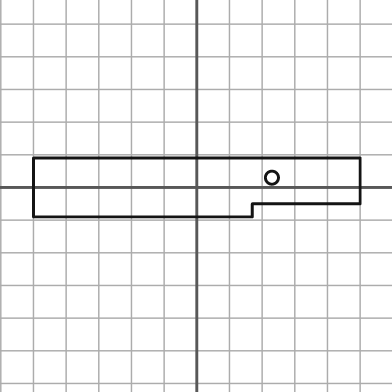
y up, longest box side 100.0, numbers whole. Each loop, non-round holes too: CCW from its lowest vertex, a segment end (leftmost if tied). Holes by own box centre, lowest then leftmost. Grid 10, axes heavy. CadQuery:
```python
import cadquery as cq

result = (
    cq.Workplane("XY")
    .moveTo(-50.0, -9.0)
    .lineTo(17.0, -9.0)
    .lineTo(17.0, -5.0)
    .lineTo(50.0, -5.0)
    .lineTo(50.0, 9.0)
    .lineTo(-50.0, 9.0)
    .close()
    .moveTo(23.0, 3.0)
    .circle(2.0)
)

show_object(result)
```